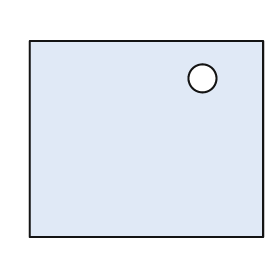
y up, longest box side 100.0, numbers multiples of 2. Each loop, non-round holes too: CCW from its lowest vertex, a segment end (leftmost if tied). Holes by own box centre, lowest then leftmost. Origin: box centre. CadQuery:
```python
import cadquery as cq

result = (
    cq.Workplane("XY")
    .moveTo(-50.0, -42.0)
    .lineTo(50.0, -42.0)
    .lineTo(50.0, 42.0)
    .lineTo(-50.0, 42.0)
    .close()
    .moveTo(24.0, 26.0)
    .circle(6.0)
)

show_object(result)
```